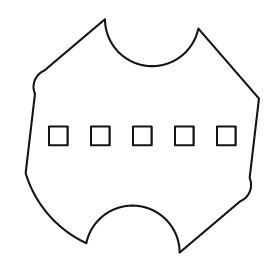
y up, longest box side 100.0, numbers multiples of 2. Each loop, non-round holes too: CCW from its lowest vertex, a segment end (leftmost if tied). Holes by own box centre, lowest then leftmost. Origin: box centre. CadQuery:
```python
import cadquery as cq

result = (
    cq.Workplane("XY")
    .moveTo(16.0, -50.0)
    .lineTo(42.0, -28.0)
    .threePointArc((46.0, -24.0), (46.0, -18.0))
    .lineTo(50.0, 16.0)
    .lineTo(24.0, 46.0)
    .threePointArc((2.0, 30.0), (-16.0, 50.0))
    .lineTo(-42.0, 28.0)
    .threePointArc((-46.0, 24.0), (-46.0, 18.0))
    .lineTo(-50.0, -16.0)
    .threePointArc((-40.0, -34.0), (-24.0, -46.0))
    .threePointArc((-2.0, -30.0), (16.0, -50.0))
    .close()
    .moveTo(-40.0, -4.0)
    .lineTo(-32.0, -4.0)
    .lineTo(-32.0, 4.0)
    .lineTo(-40.0, 4.0)
    .close()
    .moveTo(-22.0, -4.0)
    .lineTo(-14.0, -4.0)
    .lineTo(-14.0, 4.0)
    .lineTo(-22.0, 4.0)
    .close()
    .moveTo(-4.0, -4.0)
    .lineTo(4.0, -4.0)
    .lineTo(4.0, 4.0)
    .lineTo(-4.0, 4.0)
    .close()
    .moveTo(14.0, -4.0)
    .lineTo(22.0, -4.0)
    .lineTo(22.0, 4.0)
    .lineTo(14.0, 4.0)
    .close()
    .moveTo(32.0, -4.0)
    .lineTo(40.0, -4.0)
    .lineTo(40.0, 4.0)
    .lineTo(32.0, 4.0)
    .close()
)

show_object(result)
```